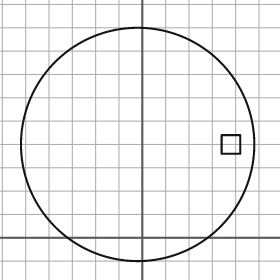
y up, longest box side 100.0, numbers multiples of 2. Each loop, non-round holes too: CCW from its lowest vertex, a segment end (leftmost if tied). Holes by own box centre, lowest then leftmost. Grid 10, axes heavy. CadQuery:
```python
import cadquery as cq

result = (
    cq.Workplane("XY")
    .moveTo(-2.0, 40.0)
    .circle(50.0)
    .moveTo(34.0, 36.0)
    .lineTo(42.0, 36.0)
    .lineTo(42.0, 44.0)
    .lineTo(34.0, 44.0)
    .close()
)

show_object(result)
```